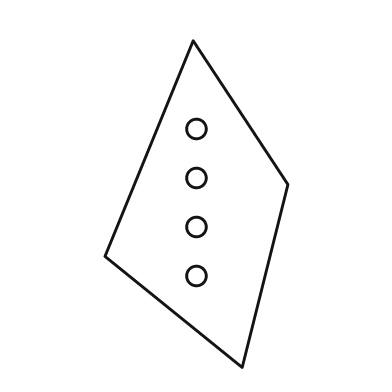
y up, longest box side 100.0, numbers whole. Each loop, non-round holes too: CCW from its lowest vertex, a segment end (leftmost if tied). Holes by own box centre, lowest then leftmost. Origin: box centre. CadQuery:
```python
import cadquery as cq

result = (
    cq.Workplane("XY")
    .moveTo(14.0, -50.0)
    .lineTo(28.0, 6.0)
    .lineTo(-1.0, 50.0)
    .lineTo(-28.0, -16.0)
    .close()
    .moveTo(0.0, -22.0)
    .circle(3.0)
    .moveTo(0.0, -7.0)
    .circle(3.0)
    .moveTo(0.0, 8.0)
    .circle(3.0)
    .moveTo(0.0, 23.0)
    .circle(3.0)
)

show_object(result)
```